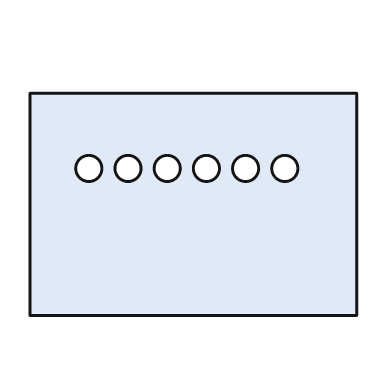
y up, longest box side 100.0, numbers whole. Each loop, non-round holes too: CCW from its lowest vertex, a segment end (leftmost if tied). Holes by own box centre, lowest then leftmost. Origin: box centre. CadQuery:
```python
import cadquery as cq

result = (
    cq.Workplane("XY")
    .moveTo(-50.0, -34.0)
    .lineTo(50.0, -34.0)
    .lineTo(50.0, 34.0)
    .lineTo(-50.0, 34.0)
    .close()
    .moveTo(-32.0, 11.0)
    .circle(4.0)
    .moveTo(-20.0, 11.0)
    .circle(4.0)
    .moveTo(-8.0, 11.0)
    .circle(4.0)
    .moveTo(4.0, 11.0)
    .circle(4.0)
    .moveTo(16.0, 11.0)
    .circle(4.0)
    .moveTo(28.0, 11.0)
    .circle(4.0)
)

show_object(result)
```